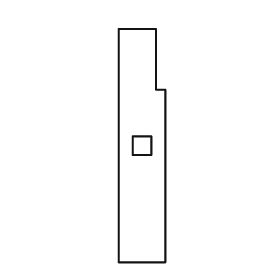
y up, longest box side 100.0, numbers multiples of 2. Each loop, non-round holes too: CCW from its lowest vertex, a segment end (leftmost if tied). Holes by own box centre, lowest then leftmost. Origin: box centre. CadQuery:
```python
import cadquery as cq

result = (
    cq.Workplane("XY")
    .moveTo(-10.0, -50.0)
    .lineTo(10.0, -50.0)
    .lineTo(10.0, 24.0)
    .lineTo(6.0, 24.0)
    .lineTo(6.0, 50.0)
    .lineTo(-10.0, 50.0)
    .close()
    .moveTo(-4.0, -4.0)
    .lineTo(4.0, -4.0)
    .lineTo(4.0, 4.0)
    .lineTo(-4.0, 4.0)
    .close()
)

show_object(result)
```